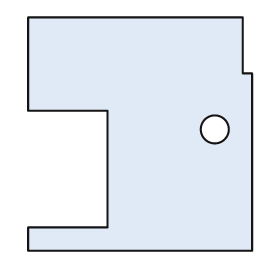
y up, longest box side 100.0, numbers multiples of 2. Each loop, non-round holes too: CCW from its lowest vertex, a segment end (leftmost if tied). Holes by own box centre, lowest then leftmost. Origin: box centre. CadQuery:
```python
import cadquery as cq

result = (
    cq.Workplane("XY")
    .moveTo(-48.0, -50.0)
    .lineTo(48.0, -50.0)
    .lineTo(48.0, 26.0)
    .lineTo(44.0, 26.0)
    .lineTo(44.0, 50.0)
    .lineTo(-48.0, 50.0)
    .lineTo(-48.0, 10.0)
    .lineTo(-14.0, 10.0)
    .lineTo(-14.0, -40.0)
    .lineTo(-48.0, -40.0)
    .close()
    .moveTo(32.0, 2.0)
    .circle(6.0)
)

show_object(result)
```